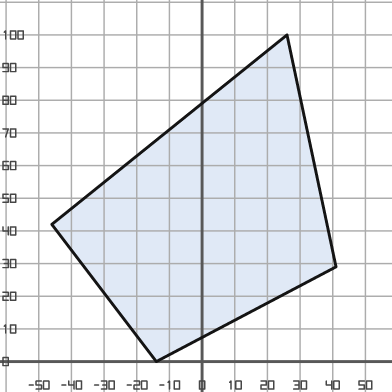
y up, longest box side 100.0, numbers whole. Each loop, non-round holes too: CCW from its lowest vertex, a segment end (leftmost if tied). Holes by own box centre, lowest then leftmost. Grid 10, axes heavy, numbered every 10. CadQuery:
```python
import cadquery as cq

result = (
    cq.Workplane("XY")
    .moveTo(-14.0, 0.0)
    .lineTo(41.0, 29.0)
    .lineTo(26.0, 100.0)
    .lineTo(-46.0, 42.0)
    .close()
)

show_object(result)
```